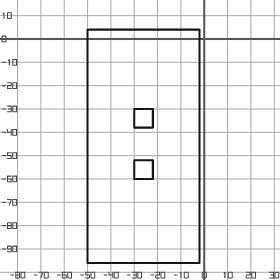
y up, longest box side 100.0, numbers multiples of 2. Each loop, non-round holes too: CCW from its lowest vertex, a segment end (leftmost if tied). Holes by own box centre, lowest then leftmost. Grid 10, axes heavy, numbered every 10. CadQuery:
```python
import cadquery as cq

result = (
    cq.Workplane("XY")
    .moveTo(-50.0, -96.0)
    .lineTo(-2.0, -96.0)
    .lineTo(-2.0, 4.0)
    .lineTo(-50.0, 4.0)
    .close()
    .moveTo(-30.0, -60.0)
    .lineTo(-22.0, -60.0)
    .lineTo(-22.0, -52.0)
    .lineTo(-30.0, -52.0)
    .close()
    .moveTo(-30.0, -38.0)
    .lineTo(-22.0, -38.0)
    .lineTo(-22.0, -30.0)
    .lineTo(-30.0, -30.0)
    .close()
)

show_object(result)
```